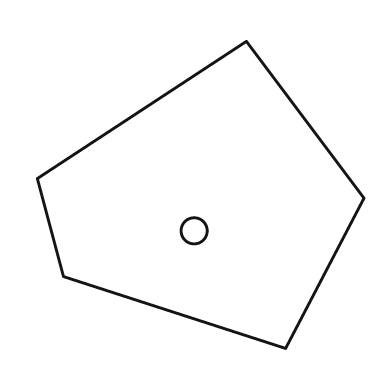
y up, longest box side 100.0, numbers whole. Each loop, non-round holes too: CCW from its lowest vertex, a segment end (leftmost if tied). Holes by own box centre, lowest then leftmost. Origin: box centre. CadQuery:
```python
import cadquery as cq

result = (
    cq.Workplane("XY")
    .moveTo(26.0, -47.0)
    .lineTo(50.0, -1.0)
    .lineTo(14.0, 47.0)
    .lineTo(-50.0, 5.0)
    .lineTo(-42.0, -25.0)
    .close()
    .moveTo(-2.0, -11.0)
    .circle(4.0)
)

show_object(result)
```